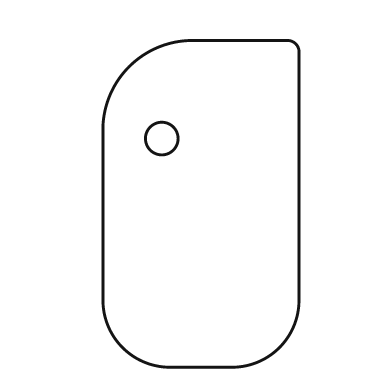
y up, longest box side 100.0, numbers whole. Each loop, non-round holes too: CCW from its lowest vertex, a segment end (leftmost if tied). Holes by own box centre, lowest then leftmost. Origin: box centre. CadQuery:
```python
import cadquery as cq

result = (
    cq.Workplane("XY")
    .moveTo(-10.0, -50.0)
    .lineTo(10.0, -50.0)
    .threePointArc((24.0, -44.0), (30.0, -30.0))
    .lineTo(30.0, 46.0)
    .threePointArc((29.0, 49.0), (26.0, 50.0))
    .lineTo(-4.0, 50.0)
    .threePointArc((-22.0, 42.0), (-30.0, 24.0))
    .lineTo(-30.0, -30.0)
    .threePointArc((-24.0, -44.0), (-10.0, -50.0))
    .close()
    .moveTo(-12.0, 20.0)
    .circle(5.0)
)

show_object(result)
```